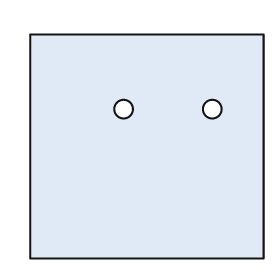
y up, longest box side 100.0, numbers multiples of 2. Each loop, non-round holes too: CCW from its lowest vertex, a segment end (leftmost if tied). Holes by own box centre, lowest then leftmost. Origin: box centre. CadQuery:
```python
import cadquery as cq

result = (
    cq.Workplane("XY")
    .moveTo(-50.0, -48.0)
    .lineTo(50.0, -48.0)
    .lineTo(50.0, 48.0)
    .lineTo(-50.0, 48.0)
    .close()
    .moveTo(-10.0, 16.0)
    .circle(4.0)
    .moveTo(28.0, 16.0)
    .circle(4.0)
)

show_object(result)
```